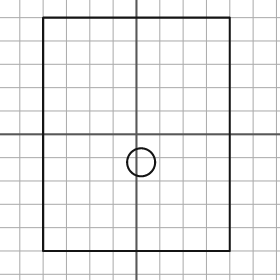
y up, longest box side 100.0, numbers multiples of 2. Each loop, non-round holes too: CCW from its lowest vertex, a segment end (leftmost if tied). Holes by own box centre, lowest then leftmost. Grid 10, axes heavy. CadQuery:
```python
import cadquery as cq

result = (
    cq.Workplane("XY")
    .moveTo(-40.0, -50.0)
    .lineTo(40.0, -50.0)
    .lineTo(40.0, 50.0)
    .lineTo(-40.0, 50.0)
    .close()
    .moveTo(2.0, -12.0)
    .circle(6.0)
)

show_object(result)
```